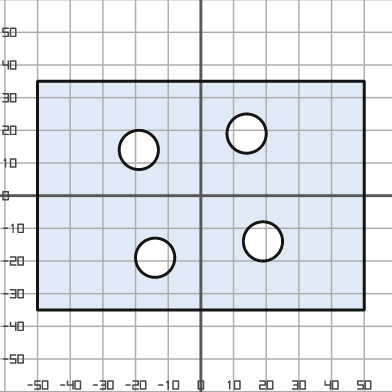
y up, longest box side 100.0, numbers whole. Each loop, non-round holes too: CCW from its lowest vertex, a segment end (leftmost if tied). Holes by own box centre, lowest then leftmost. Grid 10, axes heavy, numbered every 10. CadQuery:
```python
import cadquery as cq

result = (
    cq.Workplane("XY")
    .moveTo(-50.0, -35.0)
    .lineTo(50.0, -35.0)
    .lineTo(50.0, 35.0)
    .lineTo(-50.0, 35.0)
    .close()
    .moveTo(-14.0, -19.0)
    .circle(6.0)
    .moveTo(19.0, -14.0)
    .circle(6.0)
    .moveTo(-19.0, 14.0)
    .circle(6.0)
    .moveTo(14.0, 19.0)
    .circle(6.0)
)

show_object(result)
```